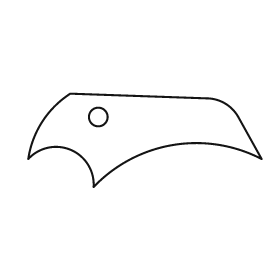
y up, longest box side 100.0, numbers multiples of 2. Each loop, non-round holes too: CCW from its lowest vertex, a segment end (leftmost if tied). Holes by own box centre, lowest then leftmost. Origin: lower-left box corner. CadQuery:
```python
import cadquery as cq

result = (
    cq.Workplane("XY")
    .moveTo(28.0, 0.0)
    .threePointArc((62.0, 18.0), (100.0, 12.0))
    .lineTo(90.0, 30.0)
    .threePointArc((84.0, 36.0), (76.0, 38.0))
    .lineTo(18.0, 40.0)
    .threePointArc((6.0, 28.0), (0.0, 12.0))
    .threePointArc((18.0, 16.0), (28.0, 0.0))
    .close()
    .moveTo(30.0, 30.0)
    .circle(4.0)
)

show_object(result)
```